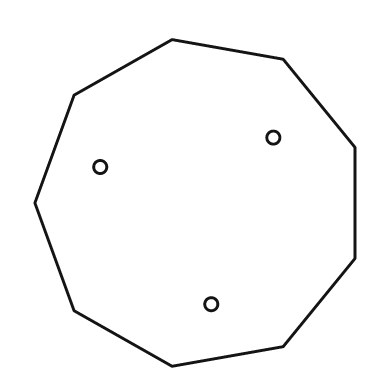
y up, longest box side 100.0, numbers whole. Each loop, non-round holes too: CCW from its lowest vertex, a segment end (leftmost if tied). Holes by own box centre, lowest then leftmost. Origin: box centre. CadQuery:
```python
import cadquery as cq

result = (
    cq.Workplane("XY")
    .moveTo(-7.0, -50.0)
    .lineTo(27.0, -44.0)
    .lineTo(49.0, -17.0)
    .lineTo(49.0, 17.0)
    .lineTo(27.0, 44.0)
    .lineTo(-7.0, 50.0)
    .lineTo(-37.0, 33.0)
    .lineTo(-49.0, 0.0)
    .lineTo(-37.0, -33.0)
    .close()
    .moveTo(5.0, -31.0)
    .circle(2.0)
    .moveTo(-29.0, 11.0)
    .circle(2.0)
    .moveTo(24.0, 20.0)
    .circle(2.0)
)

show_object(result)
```